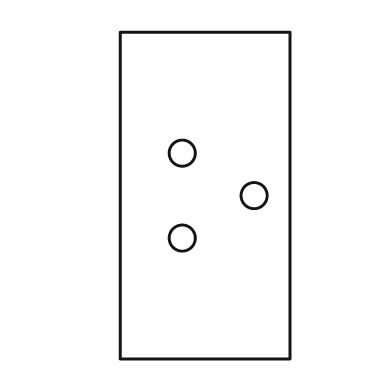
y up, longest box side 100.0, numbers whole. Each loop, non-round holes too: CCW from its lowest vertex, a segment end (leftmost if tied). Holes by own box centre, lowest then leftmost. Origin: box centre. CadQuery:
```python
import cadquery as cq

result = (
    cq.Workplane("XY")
    .moveTo(-26.0, -50.0)
    .lineTo(26.0, -50.0)
    .lineTo(26.0, 50.0)
    .lineTo(-26.0, 50.0)
    .close()
    .moveTo(-7.0, -13.0)
    .circle(4.0)
    .moveTo(15.0, 0.0)
    .circle(4.0)
    .moveTo(-7.0, 13.0)
    .circle(4.0)
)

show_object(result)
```